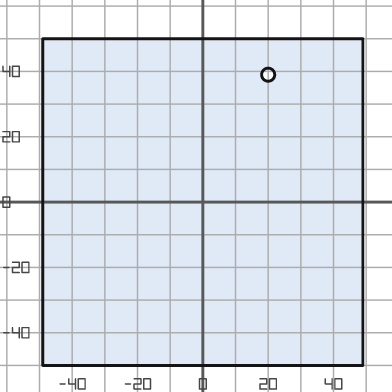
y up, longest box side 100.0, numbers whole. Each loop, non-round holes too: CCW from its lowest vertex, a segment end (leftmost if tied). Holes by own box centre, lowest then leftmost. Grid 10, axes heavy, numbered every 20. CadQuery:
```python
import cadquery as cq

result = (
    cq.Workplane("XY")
    .moveTo(-49.0, -50.0)
    .lineTo(49.0, -50.0)
    .lineTo(49.0, 50.0)
    .lineTo(-49.0, 50.0)
    .close()
    .moveTo(20.0, 39.0)
    .circle(2.0)
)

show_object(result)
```